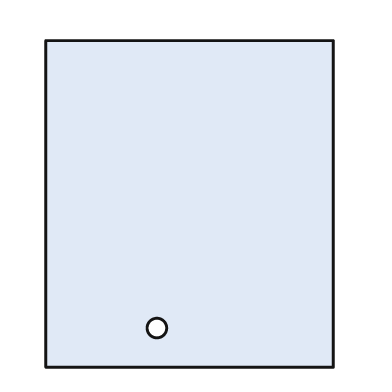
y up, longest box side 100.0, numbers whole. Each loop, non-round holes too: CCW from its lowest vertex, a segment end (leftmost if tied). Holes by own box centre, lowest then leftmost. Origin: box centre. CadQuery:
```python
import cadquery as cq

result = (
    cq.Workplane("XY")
    .moveTo(-44.0, -50.0)
    .lineTo(44.0, -50.0)
    .lineTo(44.0, 50.0)
    .lineTo(-44.0, 50.0)
    .close()
    .moveTo(-10.0, -38.0)
    .circle(3.0)
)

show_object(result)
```